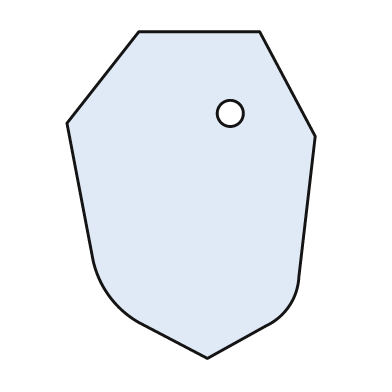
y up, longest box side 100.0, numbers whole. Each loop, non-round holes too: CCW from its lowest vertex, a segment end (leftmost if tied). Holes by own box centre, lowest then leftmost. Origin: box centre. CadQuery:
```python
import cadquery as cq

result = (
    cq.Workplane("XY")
    .moveTo(5.0, -50.0)
    .lineTo(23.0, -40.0)
    .threePointArc((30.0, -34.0), (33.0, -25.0))
    .lineTo(38.0, 18.0)
    .lineTo(21.0, 50.0)
    .lineTo(-16.0, 50.0)
    .lineTo(-38.0, 22.0)
    .lineTo(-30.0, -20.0)
    .threePointArc((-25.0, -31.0), (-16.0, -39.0))
    .close()
    .moveTo(12.0, 25.0)
    .circle(4.0)
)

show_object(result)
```